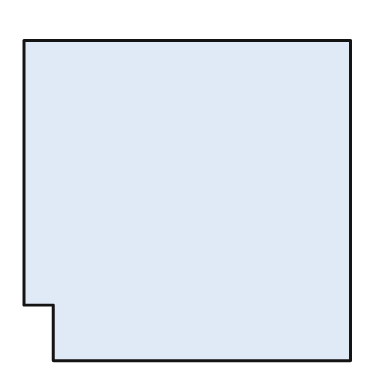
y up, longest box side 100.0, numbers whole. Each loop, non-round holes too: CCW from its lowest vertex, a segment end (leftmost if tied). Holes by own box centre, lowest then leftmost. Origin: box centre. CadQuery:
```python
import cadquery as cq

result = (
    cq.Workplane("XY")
    .moveTo(-41.0, -49.0)
    .lineTo(50.0, -49.0)
    .lineTo(50.0, 49.0)
    .lineTo(-50.0, 49.0)
    .lineTo(-50.0, -32.0)
    .lineTo(-41.0, -32.0)
    .close()
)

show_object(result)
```